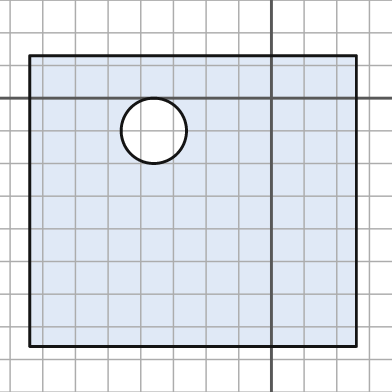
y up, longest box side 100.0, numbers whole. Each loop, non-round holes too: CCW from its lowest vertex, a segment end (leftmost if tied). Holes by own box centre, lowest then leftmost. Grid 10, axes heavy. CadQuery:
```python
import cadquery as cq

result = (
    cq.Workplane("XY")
    .moveTo(-74.0, -76.0)
    .lineTo(26.0, -76.0)
    .lineTo(26.0, 13.0)
    .lineTo(-74.0, 13.0)
    .close()
    .moveTo(-36.0, -10.0)
    .circle(10.0)
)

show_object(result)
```